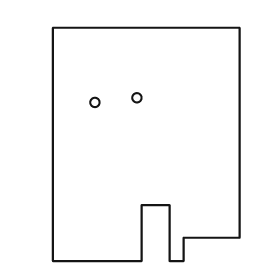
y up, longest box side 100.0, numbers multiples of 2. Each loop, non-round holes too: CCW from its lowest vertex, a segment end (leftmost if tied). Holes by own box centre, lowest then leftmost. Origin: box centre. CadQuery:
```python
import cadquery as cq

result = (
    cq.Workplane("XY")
    .moveTo(-40.0, -50.0)
    .lineTo(-2.0, -50.0)
    .lineTo(-2.0, -26.0)
    .lineTo(10.0, -26.0)
    .lineTo(10.0, -50.0)
    .lineTo(16.0, -50.0)
    .lineTo(16.0, -40.0)
    .lineTo(40.0, -40.0)
    .lineTo(40.0, 50.0)
    .lineTo(-40.0, 50.0)
    .close()
    .moveTo(-22.0, 18.0)
    .circle(2.0)
    .moveTo(-4.0, 20.0)
    .circle(2.0)
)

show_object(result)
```